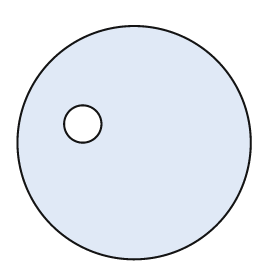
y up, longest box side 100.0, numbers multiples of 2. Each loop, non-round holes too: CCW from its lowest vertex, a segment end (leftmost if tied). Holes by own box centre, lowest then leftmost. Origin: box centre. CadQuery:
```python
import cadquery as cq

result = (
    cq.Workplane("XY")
    .moveTo(0.0, 0.0)
    .circle(50.0)
    .moveTo(-22.0, 8.0)
    .circle(8.0)
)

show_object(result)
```